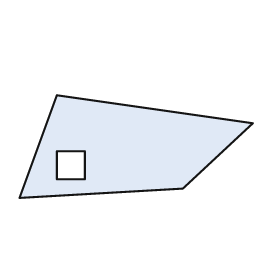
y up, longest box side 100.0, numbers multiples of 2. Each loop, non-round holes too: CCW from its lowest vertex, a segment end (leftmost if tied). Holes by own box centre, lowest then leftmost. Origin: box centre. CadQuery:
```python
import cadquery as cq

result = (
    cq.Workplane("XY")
    .moveTo(-50.0, -22.0)
    .lineTo(20.0, -18.0)
    .lineTo(50.0, 10.0)
    .lineTo(-34.0, 22.0)
    .close()
    .moveTo(-34.0, -14.0)
    .lineTo(-22.0, -14.0)
    .lineTo(-22.0, -2.0)
    .lineTo(-34.0, -2.0)
    .close()
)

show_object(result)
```